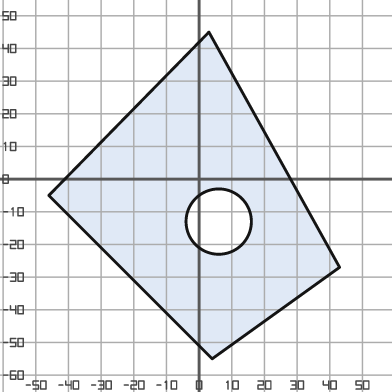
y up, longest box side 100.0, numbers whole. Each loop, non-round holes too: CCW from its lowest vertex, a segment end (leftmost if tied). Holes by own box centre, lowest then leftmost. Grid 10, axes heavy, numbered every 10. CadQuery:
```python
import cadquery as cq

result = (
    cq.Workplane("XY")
    .moveTo(4.0, -55.0)
    .lineTo(43.0, -27.0)
    .lineTo(3.0, 45.0)
    .lineTo(-46.0, -5.0)
    .close()
    .moveTo(6.0, -13.0)
    .circle(10.0)
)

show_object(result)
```